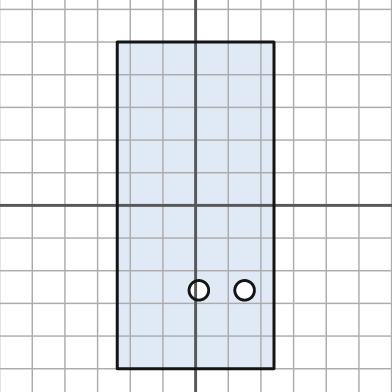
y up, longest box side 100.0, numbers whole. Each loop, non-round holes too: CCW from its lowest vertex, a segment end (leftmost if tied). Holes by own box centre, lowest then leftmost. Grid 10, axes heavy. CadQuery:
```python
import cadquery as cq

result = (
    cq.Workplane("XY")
    .moveTo(-24.0, -50.0)
    .lineTo(24.0, -50.0)
    .lineTo(24.0, 50.0)
    .lineTo(-24.0, 50.0)
    .close()
    .moveTo(1.0, -26.0)
    .circle(3.0)
    .moveTo(15.0, -26.0)
    .circle(3.0)
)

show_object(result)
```